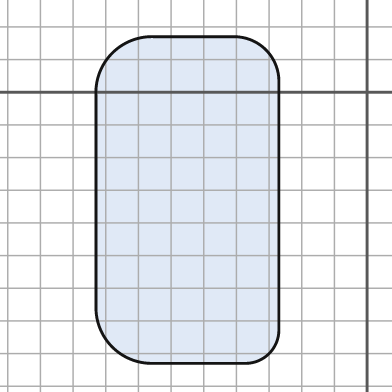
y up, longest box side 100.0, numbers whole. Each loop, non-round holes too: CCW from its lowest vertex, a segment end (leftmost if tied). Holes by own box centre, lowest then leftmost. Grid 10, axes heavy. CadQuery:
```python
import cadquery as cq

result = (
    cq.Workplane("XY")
    .moveTo(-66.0, -83.0)
    .lineTo(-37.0, -83.0)
    .threePointArc((-30.0, -80.0), (-27.0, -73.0))
    .lineTo(-27.0, 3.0)
    .threePointArc((-31.0, 13.0), (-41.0, 17.0))
    .lineTo(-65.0, 17.0)
    .threePointArc((-78.0, 12.0), (-83.0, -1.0))
    .lineTo(-83.0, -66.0)
    .threePointArc((-78.0, -78.0), (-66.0, -83.0))
    .close()
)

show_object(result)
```